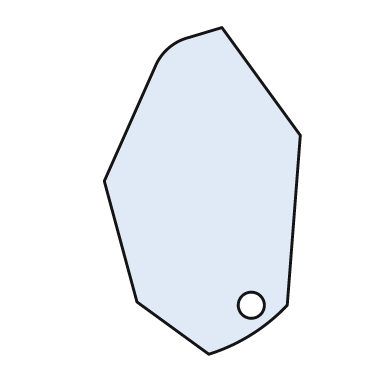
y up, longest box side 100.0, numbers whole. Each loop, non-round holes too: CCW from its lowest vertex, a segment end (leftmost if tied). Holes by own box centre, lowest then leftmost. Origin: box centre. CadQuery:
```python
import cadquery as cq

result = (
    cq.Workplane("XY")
    .moveTo(2.0, -50.0)
    .threePointArc((15.0, -44.0), (26.0, -35.0))
    .lineTo(30.0, 17.0)
    .lineTo(6.0, 50.0)
    .lineTo(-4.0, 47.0)
    .threePointArc((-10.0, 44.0), (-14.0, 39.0))
    .lineTo(-30.0, 3.0)
    .lineTo(-20.0, -34.0)
    .close()
    .moveTo(15.0, -35.0)
    .circle(4.0)
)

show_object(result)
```